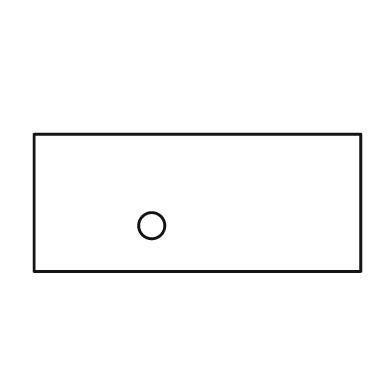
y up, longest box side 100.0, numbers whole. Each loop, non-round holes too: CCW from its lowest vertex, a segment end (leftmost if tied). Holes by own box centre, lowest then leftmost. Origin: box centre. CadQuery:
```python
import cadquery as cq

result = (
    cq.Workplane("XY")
    .moveTo(-50.0, -21.0)
    .lineTo(50.0, -21.0)
    .lineTo(50.0, 21.0)
    .lineTo(-50.0, 21.0)
    .close()
    .moveTo(-14.0, -7.0)
    .circle(4.0)
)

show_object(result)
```